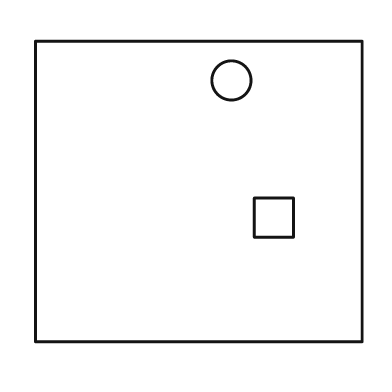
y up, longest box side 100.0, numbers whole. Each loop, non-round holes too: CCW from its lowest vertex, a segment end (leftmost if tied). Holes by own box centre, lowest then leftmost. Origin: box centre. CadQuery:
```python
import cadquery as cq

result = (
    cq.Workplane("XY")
    .moveTo(-50.0, -46.0)
    .lineTo(50.0, -46.0)
    .lineTo(50.0, 46.0)
    .lineTo(-50.0, 46.0)
    .close()
    .moveTo(17.0, -14.0)
    .lineTo(29.0, -14.0)
    .lineTo(29.0, -2.0)
    .lineTo(17.0, -2.0)
    .close()
    .moveTo(10.0, 34.0)
    .circle(6.0)
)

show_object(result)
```